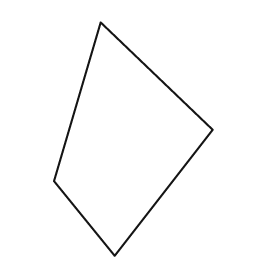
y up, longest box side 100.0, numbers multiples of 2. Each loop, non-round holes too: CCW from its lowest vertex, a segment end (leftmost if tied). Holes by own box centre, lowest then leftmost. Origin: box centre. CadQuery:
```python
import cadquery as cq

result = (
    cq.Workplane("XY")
    .moveTo(-8.0, -50.0)
    .lineTo(34.0, 4.0)
    .lineTo(-14.0, 50.0)
    .lineTo(-34.0, -18.0)
    .close()
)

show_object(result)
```